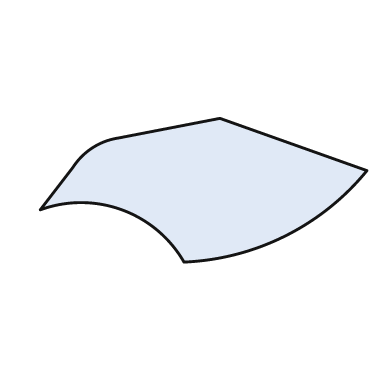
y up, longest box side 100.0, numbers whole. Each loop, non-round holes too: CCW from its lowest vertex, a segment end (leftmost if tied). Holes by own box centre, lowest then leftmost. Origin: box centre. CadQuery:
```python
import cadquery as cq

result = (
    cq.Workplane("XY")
    .moveTo(-6.0, -22.0)
    .threePointArc((25.0, -14.0), (50.0, 6.0))
    .lineTo(5.0, 22.0)
    .lineTo(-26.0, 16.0)
    .threePointArc((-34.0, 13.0), (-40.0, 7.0))
    .lineTo(-50.0, -6.0)
    .threePointArc((-25.0, -6.0), (-6.0, -22.0))
    .close()
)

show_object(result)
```